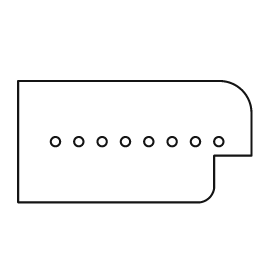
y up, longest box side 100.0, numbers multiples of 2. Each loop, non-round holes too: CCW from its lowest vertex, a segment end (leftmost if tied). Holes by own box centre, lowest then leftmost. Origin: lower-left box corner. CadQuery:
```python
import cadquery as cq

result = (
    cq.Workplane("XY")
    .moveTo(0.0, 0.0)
    .lineTo(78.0, 0.0)
    .threePointArc((82.0, 2.0), (84.0, 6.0))
    .lineTo(84.0, 20.0)
    .lineTo(100.0, 20.0)
    .lineTo(100.0, 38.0)
    .threePointArc((96.0, 48.0), (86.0, 52.0))
    .lineTo(0.0, 52.0)
    .close()
    .moveTo(16.0, 26.0)
    .circle(2.0)
    .moveTo(26.0, 26.0)
    .circle(2.0)
    .moveTo(36.0, 26.0)
    .circle(2.0)
    .moveTo(46.0, 26.0)
    .circle(2.0)
    .moveTo(56.0, 26.0)
    .circle(2.0)
    .moveTo(66.0, 26.0)
    .circle(2.0)
    .moveTo(76.0, 26.0)
    .circle(2.0)
    .moveTo(86.0, 26.0)
    .circle(2.0)
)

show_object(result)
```